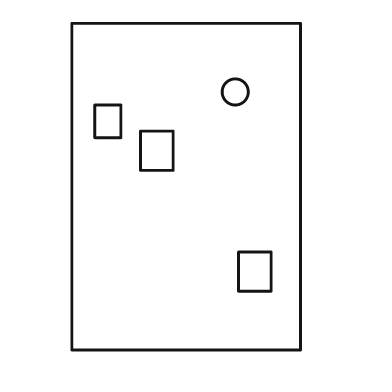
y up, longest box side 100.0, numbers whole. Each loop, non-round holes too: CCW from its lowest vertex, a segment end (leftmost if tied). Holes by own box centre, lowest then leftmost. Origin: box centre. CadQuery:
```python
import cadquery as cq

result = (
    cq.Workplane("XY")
    .moveTo(-35.0, -50.0)
    .lineTo(35.0, -50.0)
    .lineTo(35.0, 50.0)
    .lineTo(-35.0, 50.0)
    .close()
    .moveTo(16.0, -32.0)
    .lineTo(26.0, -32.0)
    .lineTo(26.0, -20.0)
    .lineTo(16.0, -20.0)
    .close()
    .moveTo(-14.0, 5.0)
    .lineTo(-4.0, 5.0)
    .lineTo(-4.0, 17.0)
    .lineTo(-14.0, 17.0)
    .close()
    .moveTo(-28.0, 15.0)
    .lineTo(-20.0, 15.0)
    .lineTo(-20.0, 25.0)
    .lineTo(-28.0, 25.0)
    .close()
    .moveTo(15.0, 29.0)
    .circle(4.0)
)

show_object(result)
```